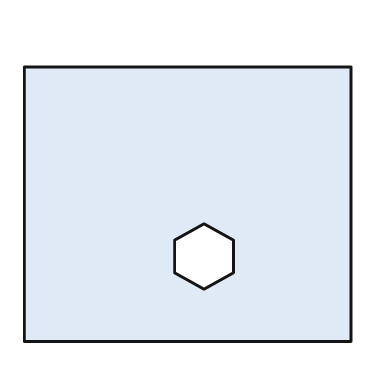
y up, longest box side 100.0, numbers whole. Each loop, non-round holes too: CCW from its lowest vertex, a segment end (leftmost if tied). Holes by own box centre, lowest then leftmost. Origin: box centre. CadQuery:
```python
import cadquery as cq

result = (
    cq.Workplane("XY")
    .moveTo(-50.0, -42.0)
    .lineTo(50.0, -42.0)
    .lineTo(50.0, 42.0)
    .lineTo(-50.0, 42.0)
    .close()
    .moveTo(5.0, -26.0)
    .lineTo(14.0, -21.0)
    .lineTo(14.0, -11.0)
    .lineTo(5.0, -6.0)
    .lineTo(-4.0, -11.0)
    .lineTo(-4.0, -21.0)
    .close()
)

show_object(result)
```